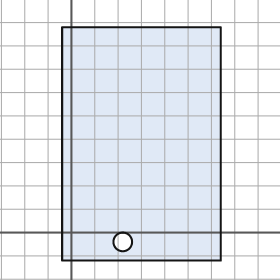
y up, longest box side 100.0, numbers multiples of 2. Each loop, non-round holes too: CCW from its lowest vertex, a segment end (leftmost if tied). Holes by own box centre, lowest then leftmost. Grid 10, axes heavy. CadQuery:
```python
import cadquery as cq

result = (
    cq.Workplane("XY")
    .moveTo(-4.0, -12.0)
    .lineTo(64.0, -12.0)
    .lineTo(64.0, 88.0)
    .lineTo(-4.0, 88.0)
    .close()
    .moveTo(22.0, -4.0)
    .circle(4.0)
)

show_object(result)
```